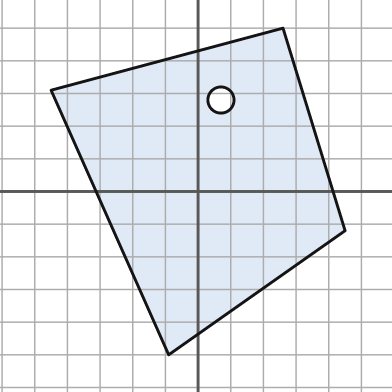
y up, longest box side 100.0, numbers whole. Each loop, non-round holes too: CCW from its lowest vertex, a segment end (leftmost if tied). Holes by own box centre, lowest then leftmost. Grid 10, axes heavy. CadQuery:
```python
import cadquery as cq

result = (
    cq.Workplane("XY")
    .moveTo(-9.0, -50.0)
    .lineTo(45.0, -12.0)
    .lineTo(26.0, 50.0)
    .lineTo(-45.0, 31.0)
    .close()
    .moveTo(7.0, 28.0)
    .circle(4.0)
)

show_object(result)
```